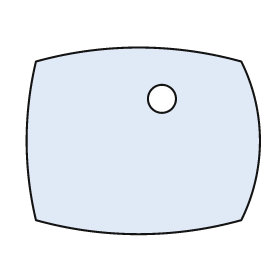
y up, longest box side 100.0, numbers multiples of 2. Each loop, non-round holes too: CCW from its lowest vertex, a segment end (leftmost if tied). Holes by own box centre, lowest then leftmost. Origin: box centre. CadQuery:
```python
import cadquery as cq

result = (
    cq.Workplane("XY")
    .moveTo(-46.0, -34.0)
    .threePointArc((-2.0, -40.0), (42.0, -34.0))
    .threePointArc((50.0, 0.0), (42.0, 34.0))
    .threePointArc((-2.0, 40.0), (-46.0, 34.0))
    .threePointArc((-50.0, 0.0), (-46.0, -34.0))
    .close()
    .moveTo(8.0, 18.0)
    .circle(6.0)
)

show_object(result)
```